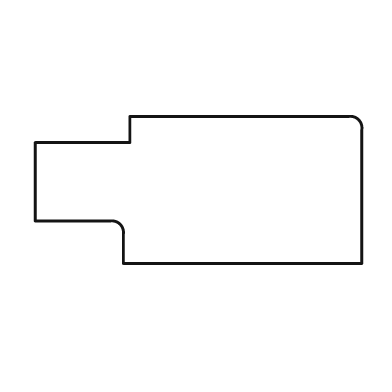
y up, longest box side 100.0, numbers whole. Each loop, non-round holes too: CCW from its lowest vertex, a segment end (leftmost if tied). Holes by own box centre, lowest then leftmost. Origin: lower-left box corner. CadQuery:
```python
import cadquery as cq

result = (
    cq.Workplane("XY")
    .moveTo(27.0, 0.0)
    .lineTo(100.0, 0.0)
    .lineTo(100.0, 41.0)
    .threePointArc((99.0, 44.0), (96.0, 45.0))
    .lineTo(29.0, 45.0)
    .lineTo(29.0, 37.0)
    .lineTo(0.0, 37.0)
    .lineTo(0.0, 13.0)
    .lineTo(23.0, 13.0)
    .threePointArc((26.0, 12.0), (27.0, 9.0))
    .close()
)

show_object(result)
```